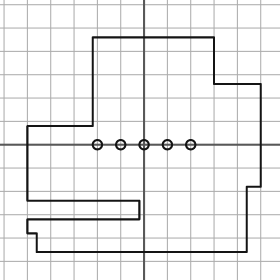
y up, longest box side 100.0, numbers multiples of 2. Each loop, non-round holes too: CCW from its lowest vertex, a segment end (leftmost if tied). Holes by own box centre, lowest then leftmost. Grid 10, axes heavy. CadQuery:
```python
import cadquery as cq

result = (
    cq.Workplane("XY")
    .moveTo(-46.0, -46.0)
    .lineTo(44.0, -46.0)
    .lineTo(44.0, -18.0)
    .lineTo(50.0, -18.0)
    .lineTo(50.0, 26.0)
    .lineTo(30.0, 26.0)
    .lineTo(30.0, 46.0)
    .lineTo(-22.0, 46.0)
    .lineTo(-22.0, 8.0)
    .lineTo(-50.0, 8.0)
    .lineTo(-50.0, -24.0)
    .lineTo(-2.0, -24.0)
    .lineTo(-2.0, -32.0)
    .lineTo(-50.0, -32.0)
    .lineTo(-50.0, -38.0)
    .lineTo(-46.0, -38.0)
    .close()
    .moveTo(-20.0, 0.0)
    .circle(2.0)
    .moveTo(-10.0, 0.0)
    .circle(2.0)
    .moveTo(0.0, 0.0)
    .circle(2.0)
    .moveTo(10.0, 0.0)
    .circle(2.0)
    .moveTo(20.0, 0.0)
    .circle(2.0)
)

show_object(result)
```